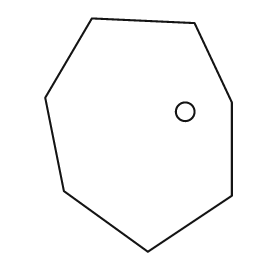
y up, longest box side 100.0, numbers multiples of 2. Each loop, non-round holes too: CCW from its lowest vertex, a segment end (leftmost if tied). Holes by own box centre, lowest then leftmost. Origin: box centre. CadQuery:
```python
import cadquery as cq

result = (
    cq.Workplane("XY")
    .moveTo(4.0, -50.0)
    .lineTo(40.0, -26.0)
    .lineTo(40.0, 14.0)
    .lineTo(24.0, 48.0)
    .lineTo(-20.0, 50.0)
    .lineTo(-40.0, 16.0)
    .lineTo(-32.0, -24.0)
    .close()
    .moveTo(20.0, 10.0)
    .circle(4.0)
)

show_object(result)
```